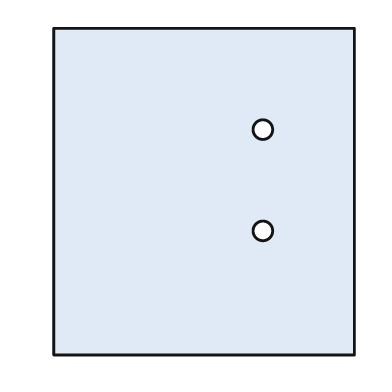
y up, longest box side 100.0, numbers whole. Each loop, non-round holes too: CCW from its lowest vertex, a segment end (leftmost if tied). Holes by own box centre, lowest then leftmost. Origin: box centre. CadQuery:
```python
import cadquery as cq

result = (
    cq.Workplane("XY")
    .moveTo(-46.0, -50.0)
    .lineTo(46.0, -50.0)
    .lineTo(46.0, 50.0)
    .lineTo(-46.0, 50.0)
    .close()
    .moveTo(18.0, -12.0)
    .circle(3.0)
    .moveTo(18.0, 19.0)
    .circle(3.0)
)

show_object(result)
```